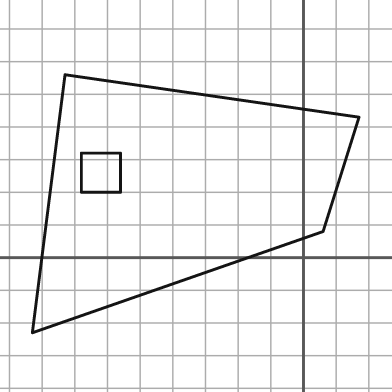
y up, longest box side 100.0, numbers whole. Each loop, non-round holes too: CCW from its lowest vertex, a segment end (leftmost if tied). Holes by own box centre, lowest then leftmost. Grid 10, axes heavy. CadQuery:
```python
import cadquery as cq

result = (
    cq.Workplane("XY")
    .moveTo(-83.0, -23.0)
    .lineTo(6.0, 8.0)
    .lineTo(17.0, 43.0)
    .lineTo(-73.0, 56.0)
    .close()
    .moveTo(-68.0, 20.0)
    .lineTo(-56.0, 20.0)
    .lineTo(-56.0, 32.0)
    .lineTo(-68.0, 32.0)
    .close()
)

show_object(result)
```